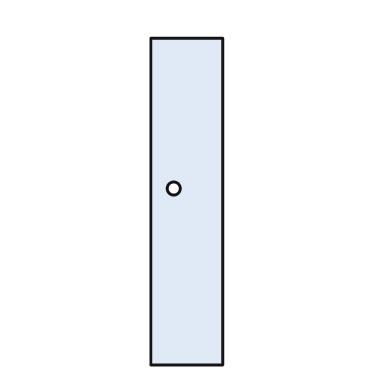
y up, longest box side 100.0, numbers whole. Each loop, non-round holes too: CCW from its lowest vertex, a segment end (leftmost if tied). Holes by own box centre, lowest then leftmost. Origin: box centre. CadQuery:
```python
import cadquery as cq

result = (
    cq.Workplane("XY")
    .moveTo(-11.0, -50.0)
    .lineTo(11.0, -50.0)
    .lineTo(11.0, 50.0)
    .lineTo(-11.0, 50.0)
    .close()
    .moveTo(-4.0, 4.0)
    .circle(2.0)
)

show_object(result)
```